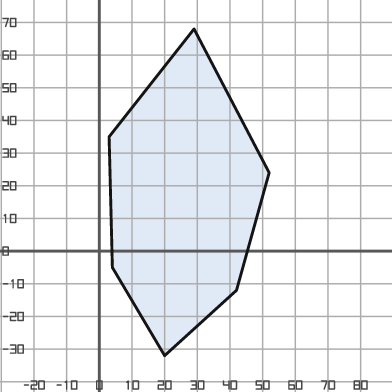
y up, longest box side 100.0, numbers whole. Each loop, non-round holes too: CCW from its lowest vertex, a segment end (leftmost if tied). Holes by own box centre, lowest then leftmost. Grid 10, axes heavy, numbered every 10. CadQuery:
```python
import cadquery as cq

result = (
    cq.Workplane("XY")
    .moveTo(20.0, -32.0)
    .lineTo(42.0, -12.0)
    .lineTo(52.0, 24.0)
    .lineTo(29.0, 68.0)
    .lineTo(3.0, 35.0)
    .lineTo(4.0, -5.0)
    .close()
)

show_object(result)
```